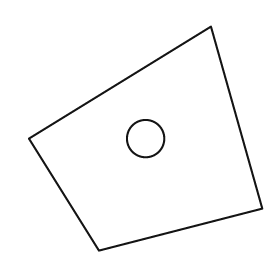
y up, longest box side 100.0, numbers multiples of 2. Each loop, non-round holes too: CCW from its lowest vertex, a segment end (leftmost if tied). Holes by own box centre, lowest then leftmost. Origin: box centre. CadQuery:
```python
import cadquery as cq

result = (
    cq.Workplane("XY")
    .moveTo(-20.0, -48.0)
    .lineTo(50.0, -30.0)
    .lineTo(28.0, 48.0)
    .lineTo(-50.0, 0.0)
    .close()
    .moveTo(0.0, 0.0)
    .circle(8.0)
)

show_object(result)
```